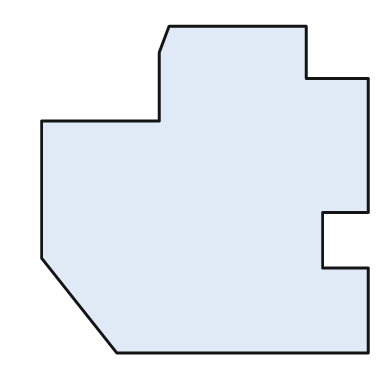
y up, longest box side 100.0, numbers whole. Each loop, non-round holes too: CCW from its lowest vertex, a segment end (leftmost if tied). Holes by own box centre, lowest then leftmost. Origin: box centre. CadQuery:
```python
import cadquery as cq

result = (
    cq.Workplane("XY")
    .moveTo(-27.0, -50.0)
    .lineTo(50.0, -50.0)
    .lineTo(50.0, -24.0)
    .lineTo(36.0, -24.0)
    .lineTo(36.0, -7.0)
    .lineTo(50.0, -7.0)
    .lineTo(50.0, 34.0)
    .lineTo(31.0, 34.0)
    .lineTo(31.0, 50.0)
    .lineTo(-11.0, 50.0)
    .lineTo(-14.0, 42.0)
    .lineTo(-14.0, 21.0)
    .lineTo(-50.0, 21.0)
    .lineTo(-50.0, -21.0)
    .close()
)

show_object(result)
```